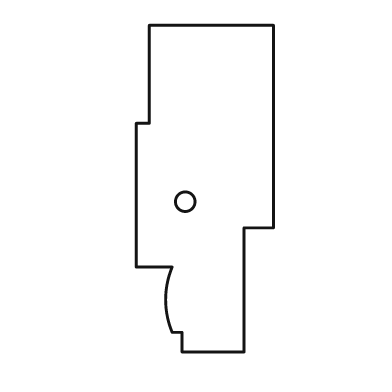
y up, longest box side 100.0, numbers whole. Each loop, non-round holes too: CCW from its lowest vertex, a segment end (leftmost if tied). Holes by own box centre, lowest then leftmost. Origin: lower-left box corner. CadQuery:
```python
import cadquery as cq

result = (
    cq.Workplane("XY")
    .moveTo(14.0, 0.0)
    .lineTo(33.0, 0.0)
    .lineTo(33.0, 38.0)
    .lineTo(42.0, 38.0)
    .lineTo(42.0, 100.0)
    .lineTo(4.0, 100.0)
    .lineTo(4.0, 70.0)
    .lineTo(0.0, 70.0)
    .lineTo(0.0, 26.0)
    .lineTo(11.0, 26.0)
    .threePointArc((9.0, 16.0), (11.0, 6.0))
    .lineTo(14.0, 6.0)
    .close()
    .moveTo(15.0, 46.0)
    .circle(3.0)
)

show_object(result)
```